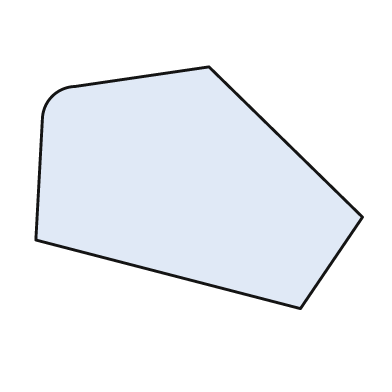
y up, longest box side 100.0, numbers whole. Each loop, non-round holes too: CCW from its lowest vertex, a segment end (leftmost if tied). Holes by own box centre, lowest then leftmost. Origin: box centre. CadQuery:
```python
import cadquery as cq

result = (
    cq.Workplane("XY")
    .moveTo(31.0, -37.0)
    .lineTo(50.0, -9.0)
    .lineTo(3.0, 37.0)
    .lineTo(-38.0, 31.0)
    .threePointArc((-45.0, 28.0), (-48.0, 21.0))
    .lineTo(-50.0, -16.0)
    .close()
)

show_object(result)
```